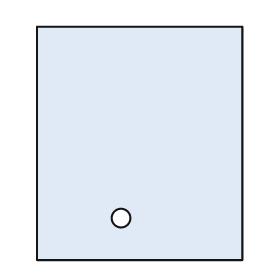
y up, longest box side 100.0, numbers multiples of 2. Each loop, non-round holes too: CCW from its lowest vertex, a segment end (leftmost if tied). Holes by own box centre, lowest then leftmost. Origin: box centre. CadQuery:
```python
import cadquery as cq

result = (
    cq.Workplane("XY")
    .moveTo(-44.0, -50.0)
    .lineTo(44.0, -50.0)
    .lineTo(44.0, 50.0)
    .lineTo(-44.0, 50.0)
    .close()
    .moveTo(-8.0, -32.0)
    .circle(4.0)
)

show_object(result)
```